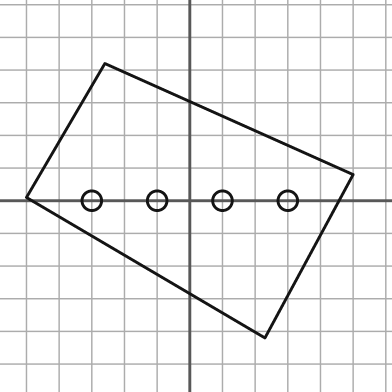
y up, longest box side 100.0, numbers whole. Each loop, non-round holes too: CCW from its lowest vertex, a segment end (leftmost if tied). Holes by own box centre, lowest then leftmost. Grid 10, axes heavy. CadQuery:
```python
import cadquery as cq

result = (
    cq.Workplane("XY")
    .moveTo(23.0, -42.0)
    .lineTo(50.0, 8.0)
    .lineTo(-26.0, 42.0)
    .lineTo(-50.0, 1.0)
    .close()
    .moveTo(-30.0, 0.0)
    .circle(3.0)
    .moveTo(-10.0, 0.0)
    .circle(3.0)
    .moveTo(10.0, 0.0)
    .circle(3.0)
    .moveTo(30.0, 0.0)
    .circle(3.0)
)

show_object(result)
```